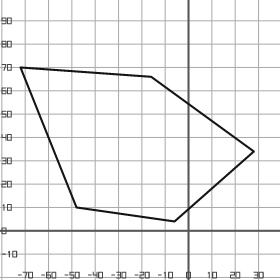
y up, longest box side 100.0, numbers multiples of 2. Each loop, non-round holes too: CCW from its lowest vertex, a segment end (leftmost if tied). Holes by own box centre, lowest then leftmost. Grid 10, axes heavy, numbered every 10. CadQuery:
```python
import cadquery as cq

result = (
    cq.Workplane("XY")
    .moveTo(-6.0, 4.0)
    .lineTo(28.0, 34.0)
    .lineTo(-16.0, 66.0)
    .lineTo(-72.0, 70.0)
    .lineTo(-48.0, 10.0)
    .close()
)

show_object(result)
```